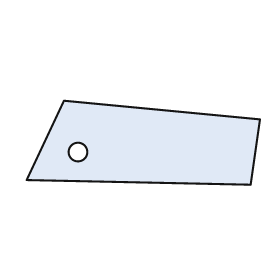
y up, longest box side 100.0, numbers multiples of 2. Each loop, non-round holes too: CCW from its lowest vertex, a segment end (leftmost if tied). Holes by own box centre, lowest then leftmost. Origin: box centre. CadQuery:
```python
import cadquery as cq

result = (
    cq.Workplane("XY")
    .moveTo(46.0, -18.0)
    .lineTo(50.0, 10.0)
    .lineTo(-34.0, 18.0)
    .lineTo(-50.0, -16.0)
    .close()
    .moveTo(-28.0, -4.0)
    .circle(4.0)
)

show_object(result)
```